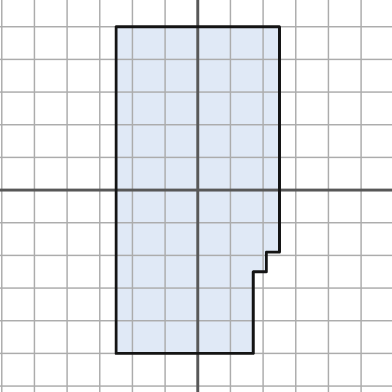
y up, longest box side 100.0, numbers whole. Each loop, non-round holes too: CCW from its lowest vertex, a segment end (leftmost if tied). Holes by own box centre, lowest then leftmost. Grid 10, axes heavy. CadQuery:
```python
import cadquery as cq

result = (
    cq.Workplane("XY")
    .moveTo(-25.0, -50.0)
    .lineTo(17.0, -50.0)
    .lineTo(17.0, -25.0)
    .lineTo(21.0, -25.0)
    .lineTo(21.0, -19.0)
    .lineTo(25.0, -19.0)
    .lineTo(25.0, 50.0)
    .lineTo(-25.0, 50.0)
    .close()
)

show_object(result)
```